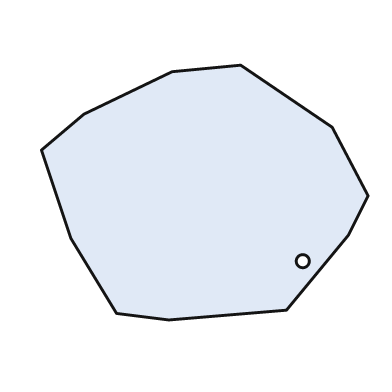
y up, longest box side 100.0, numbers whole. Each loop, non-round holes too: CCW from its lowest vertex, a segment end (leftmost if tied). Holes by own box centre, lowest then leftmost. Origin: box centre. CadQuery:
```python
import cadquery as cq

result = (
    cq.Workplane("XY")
    .moveTo(-11.0, -39.0)
    .lineTo(25.0, -36.0)
    .lineTo(44.0, -13.0)
    .lineTo(50.0, -1.0)
    .lineTo(39.0, 20.0)
    .lineTo(11.0, 39.0)
    .lineTo(-10.0, 37.0)
    .lineTo(-37.0, 24.0)
    .lineTo(-50.0, 13.0)
    .lineTo(-41.0, -14.0)
    .lineTo(-27.0, -37.0)
    .close()
    .moveTo(30.0, -21.0)
    .circle(2.0)
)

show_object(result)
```